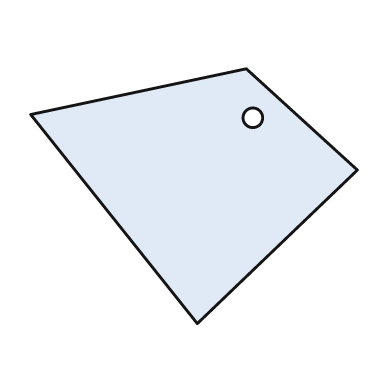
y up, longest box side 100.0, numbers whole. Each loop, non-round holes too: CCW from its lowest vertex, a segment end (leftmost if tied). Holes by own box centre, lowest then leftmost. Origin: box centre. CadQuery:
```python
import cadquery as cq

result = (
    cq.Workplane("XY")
    .moveTo(1.0, -39.0)
    .lineTo(50.0, 8.0)
    .lineTo(16.0, 39.0)
    .lineTo(-50.0, 25.0)
    .close()
    .moveTo(18.0, 24.0)
    .circle(3.0)
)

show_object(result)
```